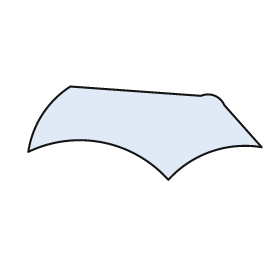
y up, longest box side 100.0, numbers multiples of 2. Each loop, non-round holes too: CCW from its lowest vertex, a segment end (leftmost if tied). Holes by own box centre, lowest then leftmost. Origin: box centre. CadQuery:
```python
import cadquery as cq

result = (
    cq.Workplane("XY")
    .moveTo(10.0, -20.0)
    .threePointArc((28.0, -8.0), (50.0, -6.0))
    .lineTo(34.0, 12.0)
    .threePointArc((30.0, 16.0), (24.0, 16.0))
    .lineTo(-32.0, 20.0)
    .threePointArc((-44.0, 8.0), (-50.0, -8.0))
    .threePointArc((-18.0, -4.0), (10.0, -20.0))
    .close()
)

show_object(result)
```